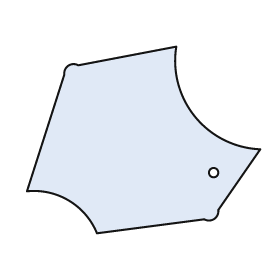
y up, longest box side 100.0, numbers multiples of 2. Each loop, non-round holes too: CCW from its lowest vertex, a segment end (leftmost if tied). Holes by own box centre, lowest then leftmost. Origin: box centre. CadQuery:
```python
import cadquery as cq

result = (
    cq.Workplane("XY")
    .moveTo(-20.0, -40.0)
    .lineTo(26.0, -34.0)
    .threePointArc((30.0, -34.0), (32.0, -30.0))
    .lineTo(50.0, -4.0)
    .threePointArc((22.0, 10.0), (14.0, 40.0))
    .lineTo(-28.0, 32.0)
    .threePointArc((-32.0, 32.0), (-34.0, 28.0))
    .lineTo(-50.0, -22.0)
    .threePointArc((-32.0, -26.0), (-20.0, -40.0))
    .close()
    .moveTo(30.0, -14.0)
    .circle(2.0)
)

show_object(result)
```